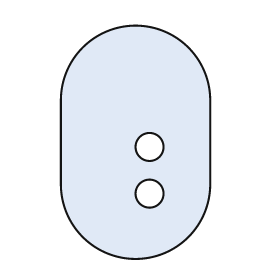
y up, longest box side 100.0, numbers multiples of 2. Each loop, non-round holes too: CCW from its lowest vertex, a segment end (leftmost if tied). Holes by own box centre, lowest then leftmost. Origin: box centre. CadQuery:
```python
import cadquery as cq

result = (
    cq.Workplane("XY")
    .moveTo(-32.0, -18.0)
    .threePointArc((0.0, -50.0), (32.0, -18.0))
    .lineTo(32.0, 18.0)
    .threePointArc((0.0, 50.0), (-32.0, 18.0))
    .close()
    .moveTo(6.0, -22.0)
    .circle(6.0)
    .moveTo(6.0, -2.0)
    .circle(6.0)
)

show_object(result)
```